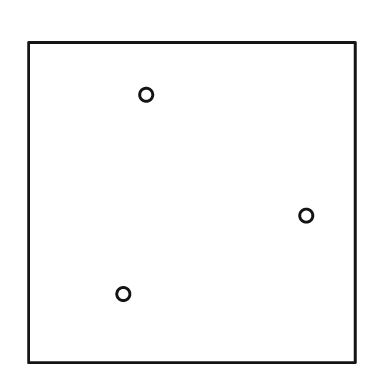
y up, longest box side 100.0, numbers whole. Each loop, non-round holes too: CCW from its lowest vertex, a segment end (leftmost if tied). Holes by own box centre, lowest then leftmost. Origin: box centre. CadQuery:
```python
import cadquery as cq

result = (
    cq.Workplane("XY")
    .moveTo(-50.0, -49.0)
    .lineTo(50.0, -49.0)
    .lineTo(50.0, 49.0)
    .lineTo(-50.0, 49.0)
    .close()
    .moveTo(-21.0, -28.0)
    .circle(2.0)
    .moveTo(35.0, -4.0)
    .circle(2.0)
    .moveTo(-14.0, 33.0)
    .circle(2.0)
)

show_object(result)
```